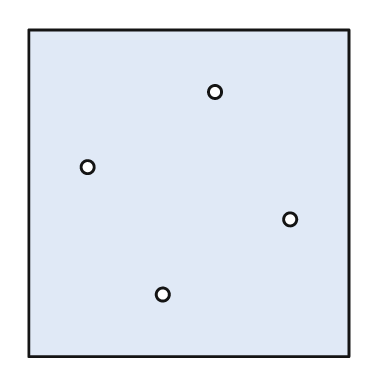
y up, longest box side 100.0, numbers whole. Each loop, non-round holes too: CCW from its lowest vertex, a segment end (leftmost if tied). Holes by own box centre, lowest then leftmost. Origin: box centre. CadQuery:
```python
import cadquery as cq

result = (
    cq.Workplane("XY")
    .moveTo(-49.0, -50.0)
    .lineTo(49.0, -50.0)
    .lineTo(49.0, 50.0)
    .lineTo(-49.0, 50.0)
    .close()
    .moveTo(-8.0, -31.0)
    .circle(2.0)
    .moveTo(31.0, -8.0)
    .circle(2.0)
    .moveTo(-31.0, 8.0)
    .circle(2.0)
    .moveTo(8.0, 31.0)
    .circle(2.0)
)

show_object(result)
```